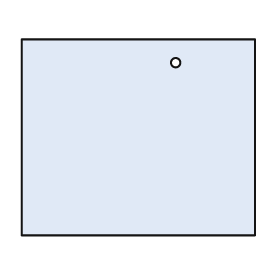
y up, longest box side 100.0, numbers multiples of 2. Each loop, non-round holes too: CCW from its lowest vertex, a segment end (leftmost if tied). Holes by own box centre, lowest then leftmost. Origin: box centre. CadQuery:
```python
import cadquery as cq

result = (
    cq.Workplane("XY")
    .moveTo(-50.0, -42.0)
    .lineTo(50.0, -42.0)
    .lineTo(50.0, 42.0)
    .lineTo(-50.0, 42.0)
    .close()
    .moveTo(16.0, 32.0)
    .circle(2.0)
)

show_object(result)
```